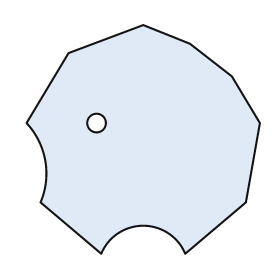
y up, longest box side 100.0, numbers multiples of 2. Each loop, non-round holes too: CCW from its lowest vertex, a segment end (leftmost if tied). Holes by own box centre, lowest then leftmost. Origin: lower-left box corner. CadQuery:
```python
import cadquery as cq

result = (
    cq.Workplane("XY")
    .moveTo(32.0, 0.0)
    .threePointArc((50.0, 12.0), (68.0, 0.0))
    .lineTo(94.0, 22.0)
    .lineTo(100.0, 56.0)
    .lineTo(88.0, 76.0)
    .lineTo(70.0, 90.0)
    .lineTo(50.0, 98.0)
    .lineTo(18.0, 86.0)
    .lineTo(0.0, 56.0)
    .threePointArc((8.0, 40.0), (6.0, 22.0))
    .close()
    .moveTo(30.0, 56.0)
    .circle(4.0)
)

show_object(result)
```